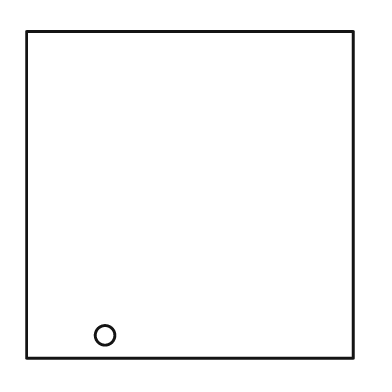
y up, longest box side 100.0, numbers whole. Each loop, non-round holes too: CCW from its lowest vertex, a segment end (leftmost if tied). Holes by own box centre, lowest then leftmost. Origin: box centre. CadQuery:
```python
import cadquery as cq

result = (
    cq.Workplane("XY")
    .moveTo(-50.0, -50.0)
    .lineTo(50.0, -50.0)
    .lineTo(50.0, 50.0)
    .lineTo(-50.0, 50.0)
    .close()
    .moveTo(-26.0, -43.0)
    .circle(3.0)
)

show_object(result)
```